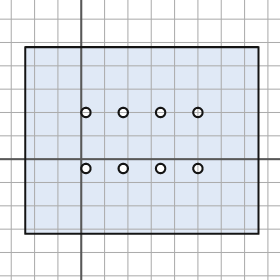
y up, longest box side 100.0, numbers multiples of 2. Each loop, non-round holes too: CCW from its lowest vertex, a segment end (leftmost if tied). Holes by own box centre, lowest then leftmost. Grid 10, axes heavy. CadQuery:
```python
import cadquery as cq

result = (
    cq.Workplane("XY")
    .moveTo(-24.0, -32.0)
    .lineTo(76.0, -32.0)
    .lineTo(76.0, 48.0)
    .lineTo(-24.0, 48.0)
    .close()
    .moveTo(2.0, -4.0)
    .circle(2.0)
    .moveTo(18.0, -4.0)
    .circle(2.0)
    .moveTo(34.0, -4.0)
    .circle(2.0)
    .moveTo(50.0, -4.0)
    .circle(2.0)
    .moveTo(2.0, 20.0)
    .circle(2.0)
    .moveTo(18.0, 20.0)
    .circle(2.0)
    .moveTo(34.0, 20.0)
    .circle(2.0)
    .moveTo(50.0, 20.0)
    .circle(2.0)
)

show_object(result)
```